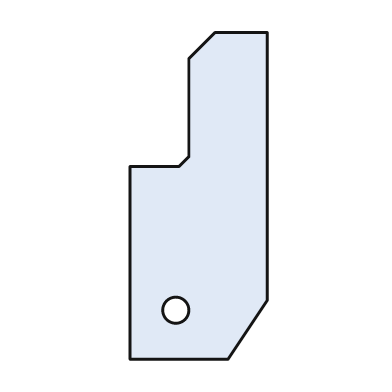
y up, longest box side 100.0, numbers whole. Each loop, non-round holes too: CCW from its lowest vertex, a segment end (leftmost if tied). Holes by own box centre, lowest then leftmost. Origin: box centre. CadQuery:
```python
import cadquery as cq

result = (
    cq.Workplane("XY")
    .moveTo(-21.0, -50.0)
    .lineTo(9.0, -50.0)
    .lineTo(21.0, -32.0)
    .lineTo(21.0, 50.0)
    .lineTo(5.0, 50.0)
    .lineTo(-3.0, 42.0)
    .lineTo(-3.0, 12.0)
    .lineTo(-6.0, 9.0)
    .lineTo(-21.0, 9.0)
    .close()
    .moveTo(-7.0, -35.0)
    .circle(4.0)
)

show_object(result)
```